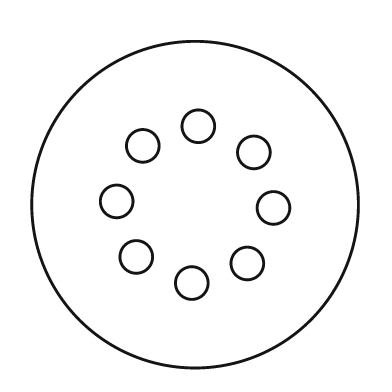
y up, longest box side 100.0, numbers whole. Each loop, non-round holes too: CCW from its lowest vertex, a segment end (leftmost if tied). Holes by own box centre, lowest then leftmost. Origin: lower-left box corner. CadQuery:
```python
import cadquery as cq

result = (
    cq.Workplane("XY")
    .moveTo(50.0, 50.0)
    .circle(50.0)
    .moveTo(49.0, 26.0)
    .circle(5.0)
    .moveTo(66.0, 32.0)
    .circle(5.0)
    .moveTo(32.0, 34.0)
    .circle(5.0)
    .moveTo(74.0, 49.0)
    .circle(5.0)
    .moveTo(26.0, 51.0)
    .circle(5.0)
    .moveTo(68.0, 66.0)
    .circle(5.0)
    .moveTo(34.0, 68.0)
    .circle(5.0)
    .moveTo(51.0, 74.0)
    .circle(5.0)
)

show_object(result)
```